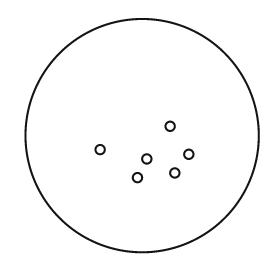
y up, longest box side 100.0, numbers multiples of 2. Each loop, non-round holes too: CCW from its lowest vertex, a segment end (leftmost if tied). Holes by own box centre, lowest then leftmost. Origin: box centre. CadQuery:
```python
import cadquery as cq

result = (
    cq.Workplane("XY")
    .moveTo(0.0, 0.0)
    .circle(50.0)
    .moveTo(-2.0, -18.0)
    .circle(2.0)
    .moveTo(14.0, -16.0)
    .circle(2.0)
    .moveTo(2.0, -10.0)
    .circle(2.0)
    .moveTo(20.0, -8.0)
    .circle(2.0)
    .moveTo(-18.0, -6.0)
    .circle(2.0)
    .moveTo(12.0, 4.0)
    .circle(2.0)
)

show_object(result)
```